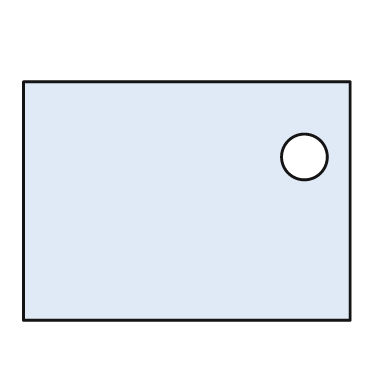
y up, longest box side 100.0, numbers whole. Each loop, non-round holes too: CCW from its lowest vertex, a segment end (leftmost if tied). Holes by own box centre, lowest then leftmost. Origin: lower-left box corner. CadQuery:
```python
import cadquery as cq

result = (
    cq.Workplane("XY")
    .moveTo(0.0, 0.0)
    .lineTo(100.0, 0.0)
    .lineTo(100.0, 73.0)
    .lineTo(0.0, 73.0)
    .close()
    .moveTo(86.0, 50.0)
    .circle(7.0)
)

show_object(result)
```